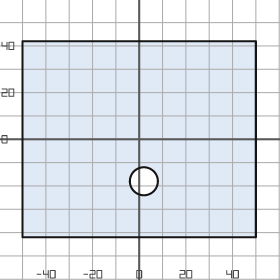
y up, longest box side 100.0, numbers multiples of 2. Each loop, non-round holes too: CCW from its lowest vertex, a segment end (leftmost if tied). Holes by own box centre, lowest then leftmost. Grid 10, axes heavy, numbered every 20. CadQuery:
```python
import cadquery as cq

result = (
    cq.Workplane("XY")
    .moveTo(-50.0, -42.0)
    .lineTo(50.0, -42.0)
    .lineTo(50.0, 42.0)
    .lineTo(-50.0, 42.0)
    .close()
    .moveTo(2.0, -18.0)
    .circle(6.0)
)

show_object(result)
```